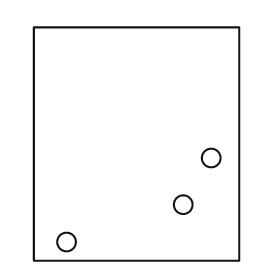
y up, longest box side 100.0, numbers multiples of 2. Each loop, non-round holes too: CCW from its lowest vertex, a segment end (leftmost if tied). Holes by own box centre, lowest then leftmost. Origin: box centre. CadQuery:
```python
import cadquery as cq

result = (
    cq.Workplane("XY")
    .moveTo(-44.0, -50.0)
    .lineTo(44.0, -50.0)
    .lineTo(44.0, 50.0)
    .lineTo(-44.0, 50.0)
    .close()
    .moveTo(-30.0, -42.0)
    .circle(4.0)
    .moveTo(20.0, -26.0)
    .circle(4.0)
    .moveTo(32.0, -6.0)
    .circle(4.0)
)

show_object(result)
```